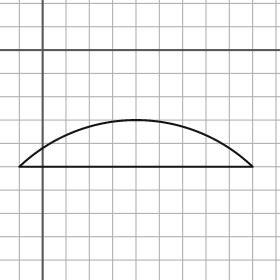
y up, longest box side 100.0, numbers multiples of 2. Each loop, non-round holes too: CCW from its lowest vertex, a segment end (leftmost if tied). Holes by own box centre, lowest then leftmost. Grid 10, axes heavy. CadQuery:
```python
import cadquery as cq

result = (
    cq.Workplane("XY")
    .moveTo(-10.0, -50.0)
    .lineTo(90.0, -50.0)
    .threePointArc((40.0, -30.0), (-10.0, -50.0))
    .close()
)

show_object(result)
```